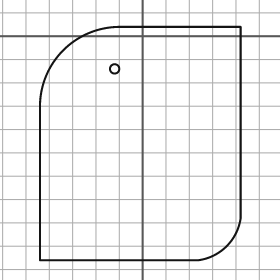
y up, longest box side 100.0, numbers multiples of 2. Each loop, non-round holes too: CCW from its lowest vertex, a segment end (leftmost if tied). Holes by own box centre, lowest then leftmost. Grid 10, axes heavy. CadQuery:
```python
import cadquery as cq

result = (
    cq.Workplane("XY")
    .moveTo(-44.0, -96.0)
    .lineTo(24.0, -96.0)
    .threePointArc((36.0, -90.0), (42.0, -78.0))
    .lineTo(42.0, 4.0)
    .lineTo(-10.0, 4.0)
    .threePointArc((-34.0, -6.0), (-44.0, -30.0))
    .close()
    .moveTo(-12.0, -14.0)
    .circle(2.0)
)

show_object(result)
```